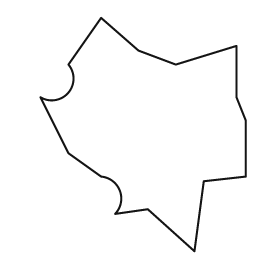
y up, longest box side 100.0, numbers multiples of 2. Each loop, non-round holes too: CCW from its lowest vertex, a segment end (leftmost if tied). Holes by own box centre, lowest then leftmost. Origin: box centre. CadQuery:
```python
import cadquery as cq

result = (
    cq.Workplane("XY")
    .moveTo(22.0, -50.0)
    .lineTo(26.0, -20.0)
    .lineTo(44.0, -18.0)
    .lineTo(44.0, 6.0)
    .lineTo(40.0, 16.0)
    .lineTo(40.0, 38.0)
    .lineTo(14.0, 30.0)
    .lineTo(-2.0, 36.0)
    .lineTo(-18.0, 50.0)
    .lineTo(-32.0, 30.0)
    .threePointArc((-32.0, 18.0), (-44.0, 16.0))
    .lineTo(-32.0, -8.0)
    .lineTo(-18.0, -18.0)
    .threePointArc((-10.0, -24.0), (-12.0, -34.0))
    .lineTo(2.0, -32.0)
    .close()
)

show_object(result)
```